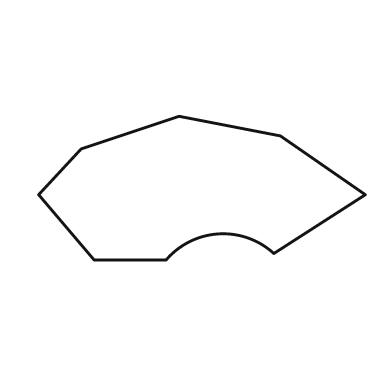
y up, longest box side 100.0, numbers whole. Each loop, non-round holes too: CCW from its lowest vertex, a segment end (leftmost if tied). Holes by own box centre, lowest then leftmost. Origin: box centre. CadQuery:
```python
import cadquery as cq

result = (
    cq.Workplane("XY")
    .moveTo(-33.0, -22.0)
    .lineTo(-11.0, -22.0)
    .threePointArc((5.0, -14.0), (22.0, -20.0))
    .lineTo(50.0, -2.0)
    .lineTo(24.0, 16.0)
    .lineTo(-7.0, 22.0)
    .lineTo(-37.0, 12.0)
    .lineTo(-50.0, -2.0)
    .close()
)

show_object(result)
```